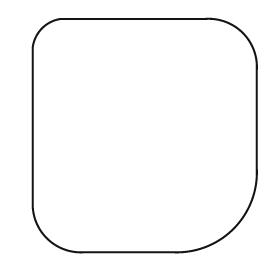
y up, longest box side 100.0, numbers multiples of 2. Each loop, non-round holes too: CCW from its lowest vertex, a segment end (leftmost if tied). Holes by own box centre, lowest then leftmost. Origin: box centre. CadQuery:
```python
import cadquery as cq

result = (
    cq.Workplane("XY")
    .moveTo(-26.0, -50.0)
    .lineTo(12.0, -50.0)
    .threePointArc((38.0, -40.0), (48.0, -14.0))
    .lineTo(48.0, 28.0)
    .threePointArc((42.0, 44.0), (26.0, 50.0))
    .lineTo(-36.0, 50.0)
    .threePointArc((-44.0, 46.0), (-48.0, 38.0))
    .lineTo(-48.0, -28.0)
    .threePointArc((-42.0, -44.0), (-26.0, -50.0))
    .close()
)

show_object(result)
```